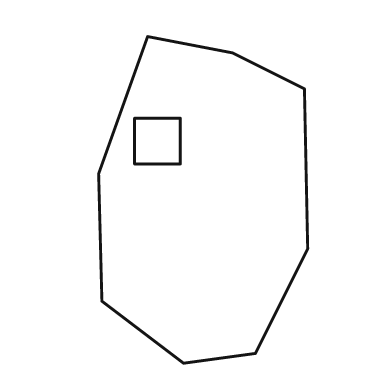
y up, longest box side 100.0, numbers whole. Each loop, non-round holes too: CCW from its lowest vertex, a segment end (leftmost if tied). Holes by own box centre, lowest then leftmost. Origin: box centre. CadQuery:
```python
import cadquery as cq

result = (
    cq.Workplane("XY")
    .moveTo(-6.0, -50.0)
    .lineTo(16.0, -47.0)
    .lineTo(32.0, -15.0)
    .lineTo(31.0, 34.0)
    .lineTo(9.0, 45.0)
    .lineTo(-17.0, 50.0)
    .lineTo(-32.0, 8.0)
    .lineTo(-31.0, -31.0)
    .close()
    .moveTo(-21.0, 11.0)
    .lineTo(-7.0, 11.0)
    .lineTo(-7.0, 25.0)
    .lineTo(-21.0, 25.0)
    .close()
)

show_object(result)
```